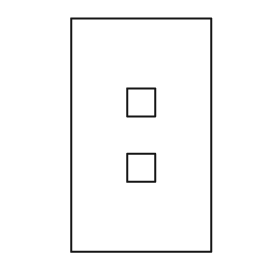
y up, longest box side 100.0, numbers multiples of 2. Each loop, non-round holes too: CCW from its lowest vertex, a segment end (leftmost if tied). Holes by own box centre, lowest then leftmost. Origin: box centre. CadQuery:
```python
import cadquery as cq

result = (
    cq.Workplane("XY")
    .moveTo(-30.0, -50.0)
    .lineTo(30.0, -50.0)
    .lineTo(30.0, 50.0)
    .lineTo(-30.0, 50.0)
    .close()
    .moveTo(-6.0, -20.0)
    .lineTo(6.0, -20.0)
    .lineTo(6.0, -8.0)
    .lineTo(-6.0, -8.0)
    .close()
    .moveTo(-6.0, 8.0)
    .lineTo(6.0, 8.0)
    .lineTo(6.0, 20.0)
    .lineTo(-6.0, 20.0)
    .close()
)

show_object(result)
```